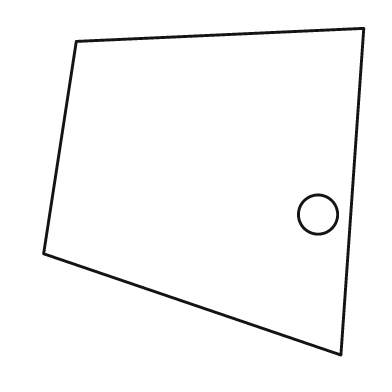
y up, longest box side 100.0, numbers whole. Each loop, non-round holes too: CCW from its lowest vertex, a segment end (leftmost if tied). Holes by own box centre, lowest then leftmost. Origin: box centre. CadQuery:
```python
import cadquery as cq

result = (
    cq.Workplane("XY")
    .moveTo(42.0, -50.0)
    .lineTo(49.0, 50.0)
    .lineTo(-39.0, 46.0)
    .lineTo(-49.0, -19.0)
    .close()
    .moveTo(35.0, -7.0)
    .circle(6.0)
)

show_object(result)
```